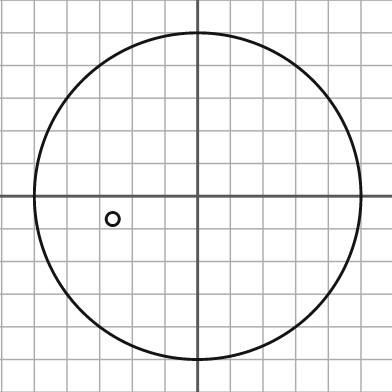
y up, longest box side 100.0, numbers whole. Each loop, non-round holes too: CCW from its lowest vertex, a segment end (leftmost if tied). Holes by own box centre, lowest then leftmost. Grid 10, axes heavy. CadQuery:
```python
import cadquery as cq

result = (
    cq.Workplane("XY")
    .moveTo(0.0, 0.0)
    .circle(50.0)
    .moveTo(-26.0, -7.0)
    .circle(2.0)
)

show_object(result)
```